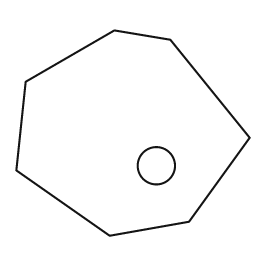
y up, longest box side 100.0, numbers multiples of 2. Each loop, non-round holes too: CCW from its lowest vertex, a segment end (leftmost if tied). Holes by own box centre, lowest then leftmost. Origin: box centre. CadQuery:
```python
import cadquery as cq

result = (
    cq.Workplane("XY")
    .moveTo(-10.0, -44.0)
    .lineTo(24.0, -38.0)
    .lineTo(50.0, -2.0)
    .lineTo(16.0, 40.0)
    .lineTo(-8.0, 44.0)
    .lineTo(-46.0, 22.0)
    .lineTo(-50.0, -16.0)
    .close()
    .moveTo(10.0, -14.0)
    .circle(8.0)
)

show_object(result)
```